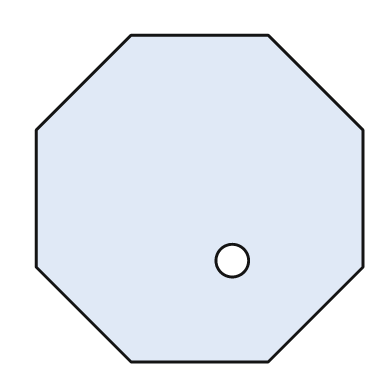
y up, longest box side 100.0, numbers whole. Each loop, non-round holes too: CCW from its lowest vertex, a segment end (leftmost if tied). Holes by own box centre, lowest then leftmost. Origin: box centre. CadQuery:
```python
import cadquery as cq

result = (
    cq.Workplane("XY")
    .moveTo(-21.0, -50.0)
    .lineTo(21.0, -50.0)
    .lineTo(50.0, -21.0)
    .lineTo(50.0, 21.0)
    .lineTo(21.0, 50.0)
    .lineTo(-21.0, 50.0)
    .lineTo(-50.0, 21.0)
    .lineTo(-50.0, -21.0)
    .close()
    .moveTo(10.0, -19.0)
    .circle(5.0)
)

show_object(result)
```